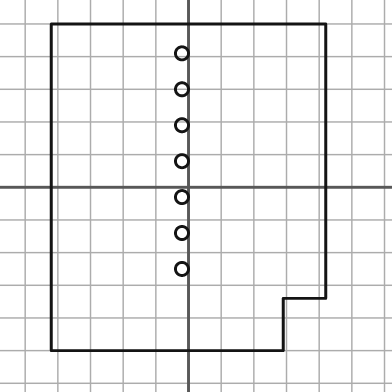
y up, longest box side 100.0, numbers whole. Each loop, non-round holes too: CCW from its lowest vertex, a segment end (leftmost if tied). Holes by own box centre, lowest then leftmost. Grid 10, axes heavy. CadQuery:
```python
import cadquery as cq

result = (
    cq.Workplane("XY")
    .moveTo(-42.0, -50.0)
    .lineTo(29.0, -50.0)
    .lineTo(29.0, -34.0)
    .lineTo(42.0, -34.0)
    .lineTo(42.0, 50.0)
    .lineTo(-42.0, 50.0)
    .close()
    .moveTo(-2.0, -25.0)
    .circle(2.0)
    .moveTo(-2.0, -14.0)
    .circle(2.0)
    .moveTo(-2.0, -3.0)
    .circle(2.0)
    .moveTo(-2.0, 8.0)
    .circle(2.0)
    .moveTo(-2.0, 19.0)
    .circle(2.0)
    .moveTo(-2.0, 30.0)
    .circle(2.0)
    .moveTo(-2.0, 41.0)
    .circle(2.0)
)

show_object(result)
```